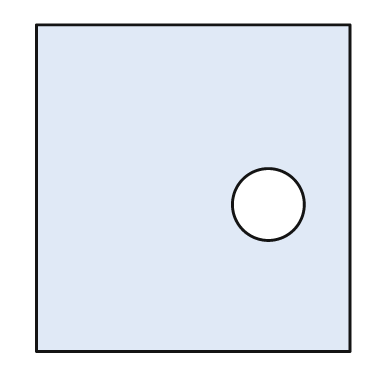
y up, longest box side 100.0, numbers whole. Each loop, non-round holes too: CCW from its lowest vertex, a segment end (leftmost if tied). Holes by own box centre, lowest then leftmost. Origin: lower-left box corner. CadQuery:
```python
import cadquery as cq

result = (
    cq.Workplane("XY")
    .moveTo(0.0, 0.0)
    .lineTo(96.0, 0.0)
    .lineTo(96.0, 100.0)
    .lineTo(0.0, 100.0)
    .close()
    .moveTo(71.0, 45.0)
    .circle(11.0)
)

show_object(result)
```